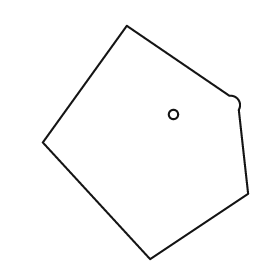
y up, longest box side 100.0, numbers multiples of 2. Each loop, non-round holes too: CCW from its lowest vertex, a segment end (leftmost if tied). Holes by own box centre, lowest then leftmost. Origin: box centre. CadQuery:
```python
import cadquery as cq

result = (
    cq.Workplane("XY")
    .moveTo(2.0, -50.0)
    .lineTo(44.0, -22.0)
    .lineTo(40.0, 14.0)
    .threePointArc((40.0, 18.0), (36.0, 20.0))
    .lineTo(-8.0, 50.0)
    .lineTo(-44.0, 0.0)
    .close()
    .moveTo(12.0, 12.0)
    .circle(2.0)
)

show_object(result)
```